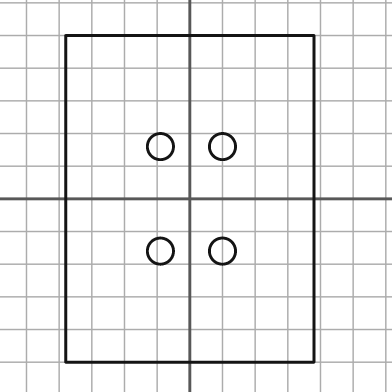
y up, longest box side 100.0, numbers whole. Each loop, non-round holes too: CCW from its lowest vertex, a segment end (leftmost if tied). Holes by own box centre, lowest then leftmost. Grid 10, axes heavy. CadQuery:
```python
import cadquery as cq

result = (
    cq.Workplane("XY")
    .moveTo(-38.0, -50.0)
    .lineTo(38.0, -50.0)
    .lineTo(38.0, 50.0)
    .lineTo(-38.0, 50.0)
    .close()
    .moveTo(-9.0, -16.0)
    .circle(4.0)
    .moveTo(10.0, -16.0)
    .circle(4.0)
    .moveTo(-9.0, 16.0)
    .circle(4.0)
    .moveTo(10.0, 16.0)
    .circle(4.0)
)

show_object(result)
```